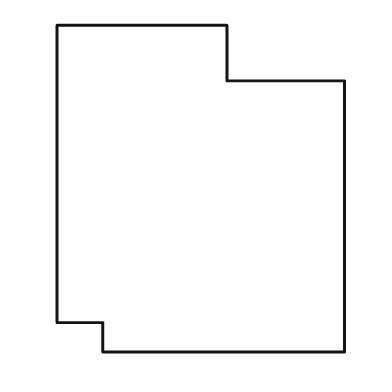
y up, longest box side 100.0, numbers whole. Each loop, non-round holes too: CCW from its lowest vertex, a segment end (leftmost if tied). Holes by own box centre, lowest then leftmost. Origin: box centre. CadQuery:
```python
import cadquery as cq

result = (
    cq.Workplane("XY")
    .moveTo(-30.0, -50.0)
    .lineTo(44.0, -50.0)
    .lineTo(44.0, 33.0)
    .lineTo(8.0, 33.0)
    .lineTo(8.0, 50.0)
    .lineTo(-44.0, 50.0)
    .lineTo(-44.0, -41.0)
    .lineTo(-30.0, -41.0)
    .close()
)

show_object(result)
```